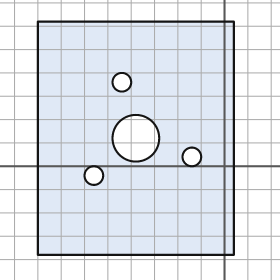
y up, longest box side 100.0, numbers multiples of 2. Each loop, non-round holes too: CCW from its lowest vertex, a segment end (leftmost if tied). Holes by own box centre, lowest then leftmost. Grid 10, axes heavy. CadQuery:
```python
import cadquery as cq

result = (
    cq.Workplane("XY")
    .moveTo(-80.0, -38.0)
    .lineTo(4.0, -38.0)
    .lineTo(4.0, 62.0)
    .lineTo(-80.0, 62.0)
    .close()
    .moveTo(-56.0, -4.0)
    .circle(4.0)
    .moveTo(-14.0, 4.0)
    .circle(4.0)
    .moveTo(-38.0, 12.0)
    .circle(10.0)
    .moveTo(-44.0, 36.0)
    .circle(4.0)
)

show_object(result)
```